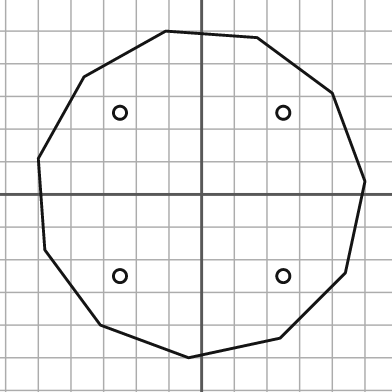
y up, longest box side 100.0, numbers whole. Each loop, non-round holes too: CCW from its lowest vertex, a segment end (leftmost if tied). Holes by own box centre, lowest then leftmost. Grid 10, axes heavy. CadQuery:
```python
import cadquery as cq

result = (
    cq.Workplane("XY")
    .moveTo(-4.0, -50.0)
    .lineTo(24.0, -44.0)
    .lineTo(44.0, -24.0)
    .lineTo(50.0, 4.0)
    .lineTo(40.0, 31.0)
    .lineTo(17.0, 48.0)
    .lineTo(-11.0, 50.0)
    .lineTo(-36.0, 36.0)
    .lineTo(-50.0, 11.0)
    .lineTo(-48.0, -17.0)
    .lineTo(-31.0, -40.0)
    .close()
    .moveTo(-25.0, -25.0)
    .circle(2.0)
    .moveTo(25.0, -25.0)
    .circle(2.0)
    .moveTo(-25.0, 25.0)
    .circle(2.0)
    .moveTo(25.0, 25.0)
    .circle(2.0)
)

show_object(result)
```